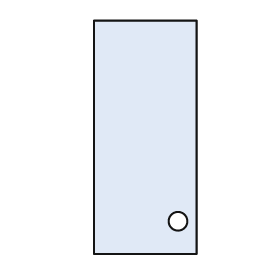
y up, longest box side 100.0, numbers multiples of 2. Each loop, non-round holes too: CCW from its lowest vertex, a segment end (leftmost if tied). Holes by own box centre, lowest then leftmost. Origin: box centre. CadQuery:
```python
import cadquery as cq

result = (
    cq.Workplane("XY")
    .moveTo(-22.0, -50.0)
    .lineTo(22.0, -50.0)
    .lineTo(22.0, 50.0)
    .lineTo(-22.0, 50.0)
    .close()
    .moveTo(14.0, -36.0)
    .circle(4.0)
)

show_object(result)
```